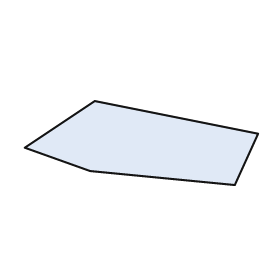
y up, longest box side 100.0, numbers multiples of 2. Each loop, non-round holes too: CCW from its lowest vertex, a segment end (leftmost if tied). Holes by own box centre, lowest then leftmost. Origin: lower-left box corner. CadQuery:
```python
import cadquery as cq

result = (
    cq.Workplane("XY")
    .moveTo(90.0, 0.0)
    .lineTo(100.0, 22.0)
    .lineTo(30.0, 36.0)
    .lineTo(0.0, 16.0)
    .lineTo(28.0, 6.0)
    .close()
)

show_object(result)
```